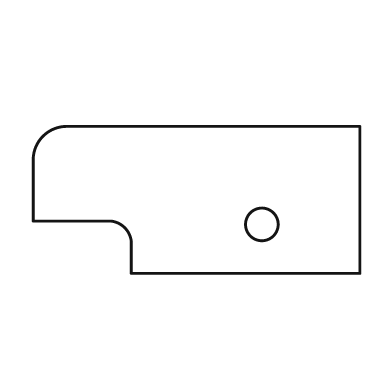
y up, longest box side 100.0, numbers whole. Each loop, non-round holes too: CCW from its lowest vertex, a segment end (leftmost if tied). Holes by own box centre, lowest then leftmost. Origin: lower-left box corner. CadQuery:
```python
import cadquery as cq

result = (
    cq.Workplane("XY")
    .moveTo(30.0, 0.0)
    .lineTo(100.0, 0.0)
    .lineTo(100.0, 45.0)
    .lineTo(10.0, 45.0)
    .threePointArc((3.0, 42.0), (0.0, 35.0))
    .lineTo(0.0, 16.0)
    .lineTo(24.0, 16.0)
    .threePointArc((28.0, 14.0), (30.0, 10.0))
    .close()
    .moveTo(70.0, 15.0)
    .circle(5.0)
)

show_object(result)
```